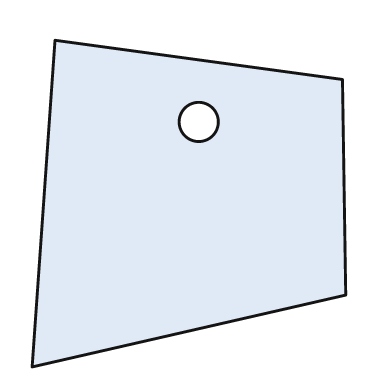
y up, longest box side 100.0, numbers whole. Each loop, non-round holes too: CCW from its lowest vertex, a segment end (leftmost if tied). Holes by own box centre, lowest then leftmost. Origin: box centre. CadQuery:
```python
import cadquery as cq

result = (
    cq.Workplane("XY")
    .moveTo(-48.0, -50.0)
    .lineTo(48.0, -28.0)
    .lineTo(47.0, 38.0)
    .lineTo(-41.0, 50.0)
    .close()
    .moveTo(3.0, 25.0)
    .circle(6.0)
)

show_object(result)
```